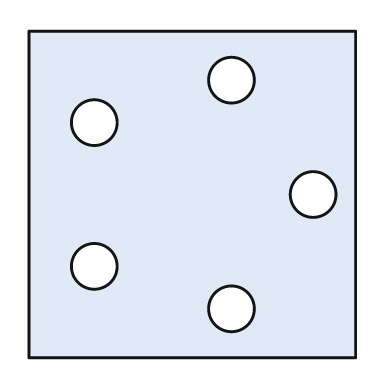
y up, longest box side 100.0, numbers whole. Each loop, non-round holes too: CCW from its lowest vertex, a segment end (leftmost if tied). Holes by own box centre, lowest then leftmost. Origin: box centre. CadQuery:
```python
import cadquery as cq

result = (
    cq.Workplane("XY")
    .moveTo(-50.0, -50.0)
    .lineTo(50.0, -50.0)
    .lineTo(50.0, 50.0)
    .lineTo(-50.0, 50.0)
    .close()
    .moveTo(12.0, -35.0)
    .circle(7.0)
    .moveTo(-30.0, -22.0)
    .circle(7.0)
    .moveTo(37.0, 0.0)
    .circle(7.0)
    .moveTo(-30.0, 22.0)
    .circle(7.0)
    .moveTo(12.0, 35.0)
    .circle(7.0)
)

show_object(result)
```